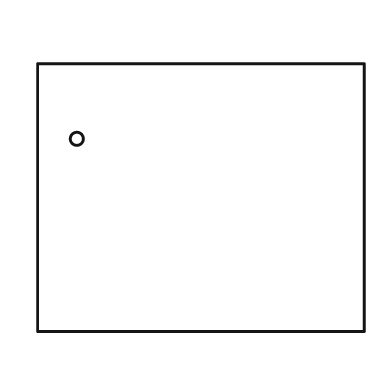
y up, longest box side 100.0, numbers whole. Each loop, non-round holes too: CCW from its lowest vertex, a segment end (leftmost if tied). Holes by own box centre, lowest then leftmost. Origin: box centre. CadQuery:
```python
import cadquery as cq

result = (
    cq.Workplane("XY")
    .moveTo(-50.0, -41.0)
    .lineTo(50.0, -41.0)
    .lineTo(50.0, 41.0)
    .lineTo(-50.0, 41.0)
    .close()
    .moveTo(-38.0, 18.0)
    .circle(2.0)
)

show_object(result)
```